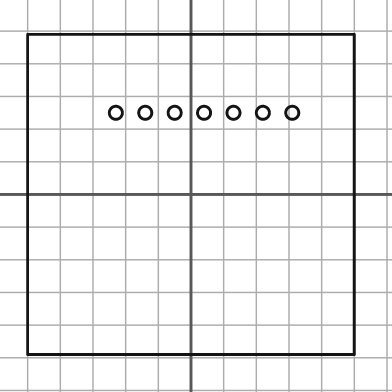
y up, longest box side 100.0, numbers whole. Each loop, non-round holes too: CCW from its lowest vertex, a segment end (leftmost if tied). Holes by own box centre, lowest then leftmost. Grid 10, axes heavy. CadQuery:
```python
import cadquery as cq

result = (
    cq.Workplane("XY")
    .moveTo(-50.0, -49.0)
    .lineTo(50.0, -49.0)
    .lineTo(50.0, 49.0)
    .lineTo(-50.0, 49.0)
    .close()
    .moveTo(-23.0, 25.0)
    .circle(2.0)
    .moveTo(-14.0, 25.0)
    .circle(2.0)
    .moveTo(-5.0, 25.0)
    .circle(2.0)
    .moveTo(4.0, 25.0)
    .circle(2.0)
    .moveTo(13.0, 25.0)
    .circle(2.0)
    .moveTo(22.0, 25.0)
    .circle(2.0)
    .moveTo(31.0, 25.0)
    .circle(2.0)
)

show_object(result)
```